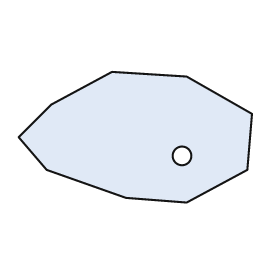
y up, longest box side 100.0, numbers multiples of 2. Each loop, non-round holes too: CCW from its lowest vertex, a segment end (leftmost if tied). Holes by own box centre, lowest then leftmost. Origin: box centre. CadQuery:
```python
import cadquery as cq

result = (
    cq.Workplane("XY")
    .moveTo(22.0, -28.0)
    .lineTo(48.0, -14.0)
    .lineTo(50.0, 10.0)
    .lineTo(22.0, 26.0)
    .lineTo(-10.0, 28.0)
    .lineTo(-36.0, 14.0)
    .lineTo(-50.0, 0.0)
    .lineTo(-38.0, -14.0)
    .lineTo(-4.0, -26.0)
    .close()
    .moveTo(20.0, -8.0)
    .circle(4.0)
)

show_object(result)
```